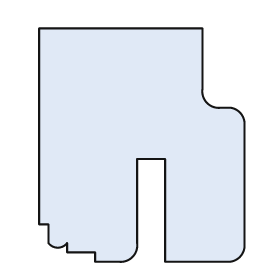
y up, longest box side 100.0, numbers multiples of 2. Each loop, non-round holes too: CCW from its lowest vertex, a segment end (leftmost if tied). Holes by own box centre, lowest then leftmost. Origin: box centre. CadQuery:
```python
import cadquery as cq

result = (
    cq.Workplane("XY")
    .moveTo(-20.0, -50.0)
    .lineTo(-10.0, -50.0)
    .threePointArc((-4.0, -48.0), (-2.0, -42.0))
    .lineTo(-2.0, -6.0)
    .lineTo(10.0, -6.0)
    .lineTo(10.0, -50.0)
    .lineTo(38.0, -50.0)
    .threePointArc((42.0, -48.0), (44.0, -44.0))
    .lineTo(44.0, 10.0)
    .threePointArc((42.0, 14.0), (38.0, 16.0))
    .lineTo(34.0, 16.0)
    .threePointArc((28.0, 18.0), (26.0, 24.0))
    .lineTo(26.0, 50.0)
    .lineTo(-44.0, 50.0)
    .lineTo(-44.0, -34.0)
    .lineTo(-40.0, -34.0)
    .lineTo(-40.0, -42.0)
    .threePointArc((-36.0, -44.0), (-32.0, -42.0))
    .lineTo(-32.0, -46.0)
    .lineTo(-20.0, -46.0)
    .close()
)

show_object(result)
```